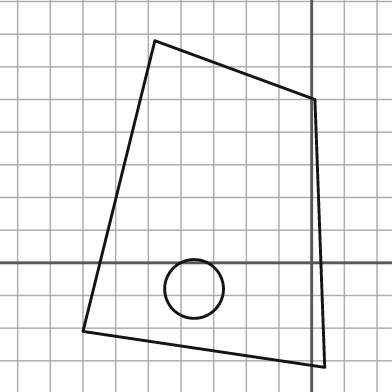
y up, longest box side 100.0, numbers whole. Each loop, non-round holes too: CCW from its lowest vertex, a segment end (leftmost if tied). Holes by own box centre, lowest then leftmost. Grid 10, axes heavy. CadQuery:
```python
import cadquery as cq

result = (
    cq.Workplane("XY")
    .moveTo(4.0, -32.0)
    .lineTo(1.0, 50.0)
    .lineTo(-48.0, 68.0)
    .lineTo(-70.0, -21.0)
    .close()
    .moveTo(-36.0, -8.0)
    .circle(9.0)
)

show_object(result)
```